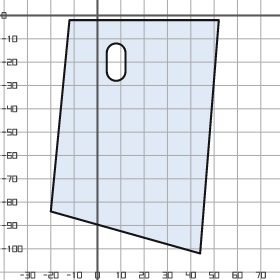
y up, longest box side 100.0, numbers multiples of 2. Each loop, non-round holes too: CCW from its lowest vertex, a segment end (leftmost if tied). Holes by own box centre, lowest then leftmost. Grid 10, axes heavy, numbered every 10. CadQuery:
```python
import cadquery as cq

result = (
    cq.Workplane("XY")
    .moveTo(44.0, -102.0)
    .lineTo(52.0, -2.0)
    .lineTo(-12.0, -2.0)
    .lineTo(-20.0, -84.0)
    .close()
    .moveTo(4.0, -24.0)
    .threePointArc((8.0, -28.0), (12.0, -24.0))
    .lineTo(12.0, -16.0)
    .threePointArc((8.0, -12.0), (4.0, -16.0))
    .close()
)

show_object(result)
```